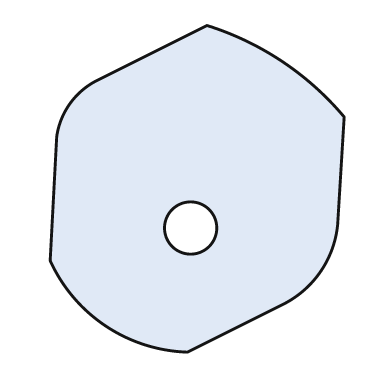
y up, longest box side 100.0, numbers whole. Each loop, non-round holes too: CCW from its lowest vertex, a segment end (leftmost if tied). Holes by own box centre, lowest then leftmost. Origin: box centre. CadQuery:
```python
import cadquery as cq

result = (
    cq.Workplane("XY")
    .moveTo(-3.0, -50.0)
    .lineTo(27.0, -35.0)
    .threePointArc((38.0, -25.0), (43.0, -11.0))
    .lineTo(45.0, 22.0)
    .threePointArc((26.0, 39.0), (3.0, 50.0))
    .lineTo(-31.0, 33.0)
    .threePointArc((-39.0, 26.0), (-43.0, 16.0))
    .lineTo(-45.0, -22.0)
    .threePointArc((-28.0, -42.0), (-3.0, -50.0))
    .close()
    .moveTo(-2.0, -12.0)
    .circle(8.0)
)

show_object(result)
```